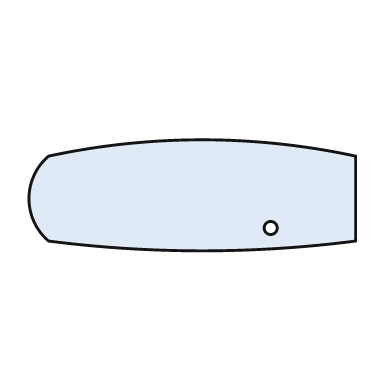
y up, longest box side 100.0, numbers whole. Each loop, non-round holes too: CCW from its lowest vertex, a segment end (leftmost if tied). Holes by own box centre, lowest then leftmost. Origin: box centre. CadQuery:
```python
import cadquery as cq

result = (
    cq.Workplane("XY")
    .moveTo(-44.0, -14.0)
    .threePointArc((3.0, -17.0), (50.0, -14.0))
    .lineTo(50.0, 12.0)
    .threePointArc((3.0, 17.0), (-44.0, 12.0))
    .threePointArc((-50.0, -1.0), (-44.0, -14.0))
    .close()
    .moveTo(24.0, -10.0)
    .circle(2.0)
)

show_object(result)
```